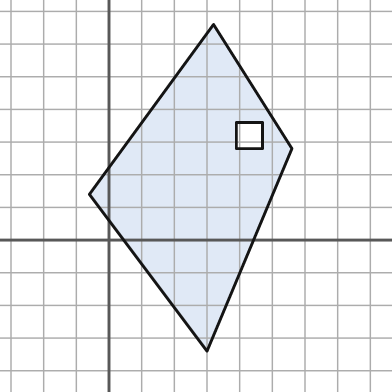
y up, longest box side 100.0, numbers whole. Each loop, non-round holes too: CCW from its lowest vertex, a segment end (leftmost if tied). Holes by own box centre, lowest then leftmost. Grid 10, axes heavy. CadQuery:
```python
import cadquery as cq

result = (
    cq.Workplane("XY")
    .moveTo(30.0, -34.0)
    .lineTo(56.0, 28.0)
    .lineTo(32.0, 66.0)
    .lineTo(-6.0, 14.0)
    .close()
    .moveTo(39.0, 28.0)
    .lineTo(47.0, 28.0)
    .lineTo(47.0, 36.0)
    .lineTo(39.0, 36.0)
    .close()
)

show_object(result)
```